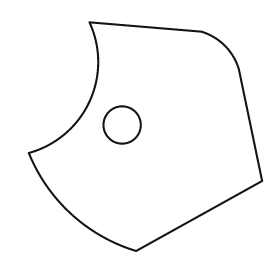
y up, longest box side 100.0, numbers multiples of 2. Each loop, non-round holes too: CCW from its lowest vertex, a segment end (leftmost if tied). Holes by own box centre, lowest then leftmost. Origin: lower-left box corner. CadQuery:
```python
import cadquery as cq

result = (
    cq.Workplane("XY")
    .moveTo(46.0, 0.0)
    .lineTo(100.0, 30.0)
    .lineTo(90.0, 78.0)
    .threePointArc((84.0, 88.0), (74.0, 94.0))
    .lineTo(26.0, 98.0)
    .threePointArc((26.0, 64.0), (0.0, 42.0))
    .threePointArc((18.0, 16.0), (46.0, 0.0))
    .close()
    .moveTo(40.0, 54.0)
    .circle(8.0)
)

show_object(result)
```